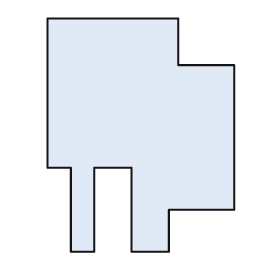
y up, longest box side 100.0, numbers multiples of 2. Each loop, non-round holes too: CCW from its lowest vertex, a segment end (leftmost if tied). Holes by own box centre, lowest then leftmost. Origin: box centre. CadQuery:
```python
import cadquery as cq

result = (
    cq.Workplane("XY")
    .moveTo(-30.0, -50.0)
    .lineTo(-20.0, -50.0)
    .lineTo(-20.0, -14.0)
    .lineTo(-4.0, -14.0)
    .lineTo(-4.0, -50.0)
    .lineTo(12.0, -50.0)
    .lineTo(12.0, -32.0)
    .lineTo(40.0, -32.0)
    .lineTo(40.0, 30.0)
    .lineTo(16.0, 30.0)
    .lineTo(16.0, 50.0)
    .lineTo(-40.0, 50.0)
    .lineTo(-40.0, -14.0)
    .lineTo(-30.0, -14.0)
    .close()
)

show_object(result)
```